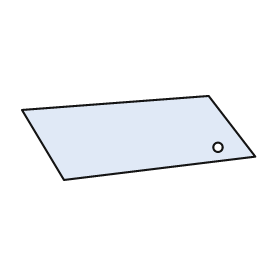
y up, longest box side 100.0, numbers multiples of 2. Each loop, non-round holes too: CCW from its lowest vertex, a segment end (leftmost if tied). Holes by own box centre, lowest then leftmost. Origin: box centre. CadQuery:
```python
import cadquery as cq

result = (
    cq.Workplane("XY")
    .moveTo(-32.0, -18.0)
    .lineTo(50.0, -8.0)
    .lineTo(30.0, 18.0)
    .lineTo(-50.0, 12.0)
    .close()
    .moveTo(34.0, -4.0)
    .circle(2.0)
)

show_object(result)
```